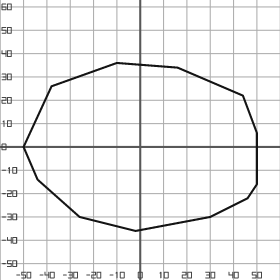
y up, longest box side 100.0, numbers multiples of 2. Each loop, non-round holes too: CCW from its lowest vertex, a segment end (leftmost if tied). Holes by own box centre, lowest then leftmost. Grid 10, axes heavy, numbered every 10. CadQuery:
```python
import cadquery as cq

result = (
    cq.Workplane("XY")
    .moveTo(-2.0, -36.0)
    .lineTo(30.0, -30.0)
    .lineTo(46.0, -22.0)
    .lineTo(50.0, -16.0)
    .lineTo(50.0, 6.0)
    .lineTo(44.0, 22.0)
    .lineTo(16.0, 34.0)
    .lineTo(-10.0, 36.0)
    .lineTo(-38.0, 26.0)
    .lineTo(-50.0, 0.0)
    .lineTo(-44.0, -14.0)
    .lineTo(-26.0, -30.0)
    .close()
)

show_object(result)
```